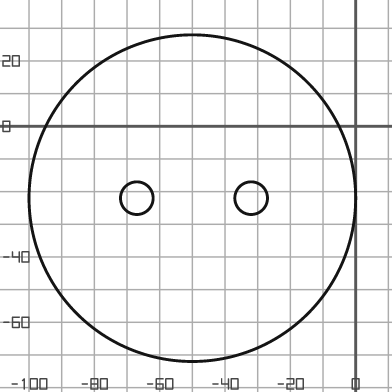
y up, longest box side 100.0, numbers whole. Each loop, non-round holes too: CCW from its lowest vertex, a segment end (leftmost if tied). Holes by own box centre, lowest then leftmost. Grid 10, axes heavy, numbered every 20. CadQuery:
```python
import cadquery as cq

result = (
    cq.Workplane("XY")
    .moveTo(-50.0, -22.0)
    .circle(50.0)
    .moveTo(-67.0, -22.0)
    .circle(5.0)
    .moveTo(-32.0, -22.0)
    .circle(5.0)
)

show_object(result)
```